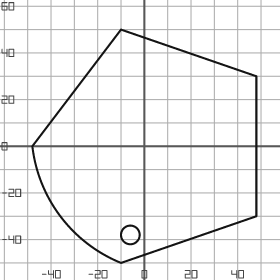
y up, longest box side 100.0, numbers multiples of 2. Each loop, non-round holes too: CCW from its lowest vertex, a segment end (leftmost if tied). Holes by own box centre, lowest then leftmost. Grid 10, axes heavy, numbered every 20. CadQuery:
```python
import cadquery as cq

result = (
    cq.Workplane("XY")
    .moveTo(-10.0, -50.0)
    .lineTo(48.0, -30.0)
    .lineTo(48.0, 30.0)
    .lineTo(-10.0, 50.0)
    .lineTo(-48.0, 0.0)
    .threePointArc((-36.0, -30.0), (-10.0, -50.0))
    .close()
    .moveTo(-6.0, -38.0)
    .circle(4.0)
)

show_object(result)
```